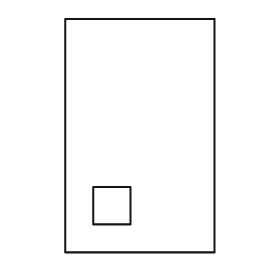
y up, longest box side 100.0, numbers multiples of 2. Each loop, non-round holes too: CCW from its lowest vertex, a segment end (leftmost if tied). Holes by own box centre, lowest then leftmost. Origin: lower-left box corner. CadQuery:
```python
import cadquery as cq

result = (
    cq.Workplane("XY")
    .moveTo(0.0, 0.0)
    .lineTo(64.0, 0.0)
    .lineTo(64.0, 100.0)
    .lineTo(0.0, 100.0)
    .close()
    .moveTo(12.0, 12.0)
    .lineTo(28.0, 12.0)
    .lineTo(28.0, 28.0)
    .lineTo(12.0, 28.0)
    .close()
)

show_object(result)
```